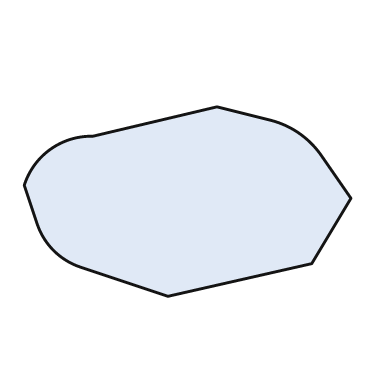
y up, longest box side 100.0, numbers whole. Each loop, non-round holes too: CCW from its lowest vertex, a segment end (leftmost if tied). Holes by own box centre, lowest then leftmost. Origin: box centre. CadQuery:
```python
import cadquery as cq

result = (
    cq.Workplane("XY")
    .moveTo(-6.0, -29.0)
    .lineTo(38.0, -19.0)
    .lineTo(50.0, 1.0)
    .lineTo(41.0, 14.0)
    .threePointArc((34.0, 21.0), (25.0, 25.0))
    .lineTo(9.0, 29.0)
    .lineTo(-29.0, 20.0)
    .threePointArc((-42.0, 16.0), (-50.0, 5.0))
    .lineTo(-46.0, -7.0)
    .threePointArc((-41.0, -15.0), (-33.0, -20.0))
    .close()
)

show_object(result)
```